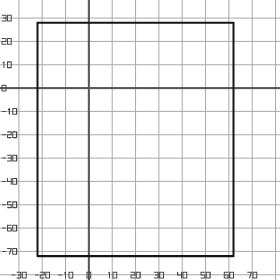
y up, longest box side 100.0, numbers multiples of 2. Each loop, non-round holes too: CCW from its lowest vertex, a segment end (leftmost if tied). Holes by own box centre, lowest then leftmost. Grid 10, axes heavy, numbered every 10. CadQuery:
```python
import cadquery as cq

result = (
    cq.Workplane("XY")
    .moveTo(-22.0, -72.0)
    .lineTo(62.0, -72.0)
    .lineTo(62.0, 28.0)
    .lineTo(-22.0, 28.0)
    .close()
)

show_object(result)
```